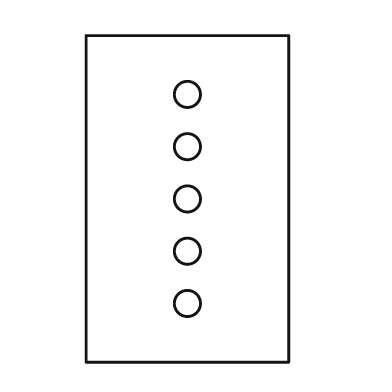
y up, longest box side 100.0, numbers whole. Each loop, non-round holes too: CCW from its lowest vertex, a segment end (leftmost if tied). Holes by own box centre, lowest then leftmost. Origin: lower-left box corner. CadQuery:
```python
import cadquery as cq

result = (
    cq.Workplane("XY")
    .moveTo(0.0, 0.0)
    .lineTo(62.0, 0.0)
    .lineTo(62.0, 100.0)
    .lineTo(0.0, 100.0)
    .close()
    .moveTo(31.0, 18.0)
    .circle(4.0)
    .moveTo(31.0, 34.0)
    .circle(4.0)
    .moveTo(31.0, 50.0)
    .circle(4.0)
    .moveTo(31.0, 66.0)
    .circle(4.0)
    .moveTo(31.0, 82.0)
    .circle(4.0)
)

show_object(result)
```